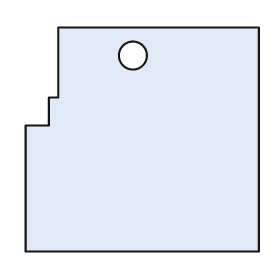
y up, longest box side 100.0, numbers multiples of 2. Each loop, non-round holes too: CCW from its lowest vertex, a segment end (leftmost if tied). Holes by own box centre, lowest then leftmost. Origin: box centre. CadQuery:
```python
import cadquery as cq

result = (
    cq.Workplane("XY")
    .moveTo(-50.0, -48.0)
    .lineTo(50.0, -48.0)
    .lineTo(50.0, 48.0)
    .lineTo(-36.0, 48.0)
    .lineTo(-36.0, 18.0)
    .lineTo(-40.0, 18.0)
    .lineTo(-40.0, 6.0)
    .lineTo(-50.0, 6.0)
    .close()
    .moveTo(-4.0, 36.0)
    .circle(6.0)
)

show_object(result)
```